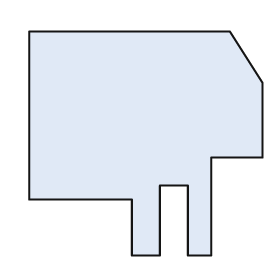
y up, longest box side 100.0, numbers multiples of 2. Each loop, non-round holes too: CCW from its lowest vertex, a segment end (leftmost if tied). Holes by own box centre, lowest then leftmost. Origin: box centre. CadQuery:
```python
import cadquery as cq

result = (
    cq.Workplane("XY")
    .moveTo(-6.0, -48.0)
    .lineTo(6.0, -48.0)
    .lineTo(6.0, -18.0)
    .lineTo(18.0, -18.0)
    .lineTo(18.0, -48.0)
    .lineTo(28.0, -48.0)
    .lineTo(28.0, -6.0)
    .lineTo(50.0, -6.0)
    .lineTo(50.0, 26.0)
    .lineTo(36.0, 48.0)
    .lineTo(-50.0, 48.0)
    .lineTo(-50.0, -24.0)
    .lineTo(-6.0, -24.0)
    .close()
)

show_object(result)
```